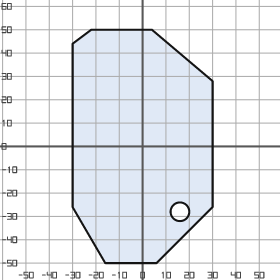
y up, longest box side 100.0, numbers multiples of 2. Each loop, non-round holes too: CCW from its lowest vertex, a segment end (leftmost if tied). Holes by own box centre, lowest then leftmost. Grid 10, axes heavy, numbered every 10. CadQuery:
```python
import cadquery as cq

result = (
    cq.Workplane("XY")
    .moveTo(-16.0, -50.0)
    .lineTo(6.0, -50.0)
    .lineTo(30.0, -26.0)
    .lineTo(30.0, 28.0)
    .lineTo(4.0, 50.0)
    .lineTo(-22.0, 50.0)
    .lineTo(-30.0, 44.0)
    .lineTo(-30.0, -26.0)
    .close()
    .moveTo(16.0, -28.0)
    .circle(4.0)
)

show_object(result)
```